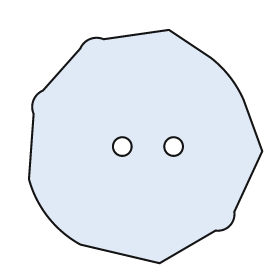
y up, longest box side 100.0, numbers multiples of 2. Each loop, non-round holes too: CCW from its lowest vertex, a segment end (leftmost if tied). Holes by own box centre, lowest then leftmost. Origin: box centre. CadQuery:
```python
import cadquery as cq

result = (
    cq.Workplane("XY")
    .moveTo(6.0, -50.0)
    .lineTo(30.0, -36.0)
    .threePointArc((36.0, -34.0), (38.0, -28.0))
    .lineTo(50.0, -2.0)
    .lineTo(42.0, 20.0)
    .threePointArc((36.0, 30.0), (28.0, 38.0))
    .lineTo(10.0, 50.0)
    .lineTo(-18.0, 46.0)
    .threePointArc((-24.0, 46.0), (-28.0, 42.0))
    .lineTo(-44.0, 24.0)
    .threePointArc((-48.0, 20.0), (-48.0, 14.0))
    .lineTo(-50.0, -14.0)
    .threePointArc((-42.0, -30.0), (-28.0, -42.0))
    .close()
    .moveTo(-10.0, 0.0)
    .circle(4.0)
    .moveTo(12.0, 0.0)
    .circle(4.0)
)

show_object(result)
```